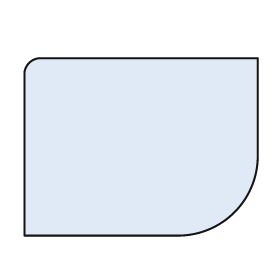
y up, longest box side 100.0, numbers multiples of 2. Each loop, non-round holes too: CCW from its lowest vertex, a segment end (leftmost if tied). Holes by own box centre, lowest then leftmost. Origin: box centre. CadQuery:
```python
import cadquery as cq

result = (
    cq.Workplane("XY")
    .moveTo(-50.0, -38.0)
    .lineTo(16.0, -38.0)
    .threePointArc((40.0, -28.0), (50.0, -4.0))
    .lineTo(50.0, 38.0)
    .lineTo(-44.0, 38.0)
    .threePointArc((-48.0, 36.0), (-50.0, 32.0))
    .close()
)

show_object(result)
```